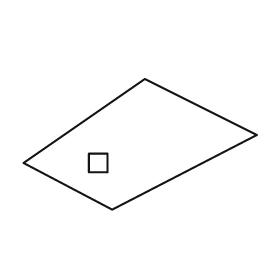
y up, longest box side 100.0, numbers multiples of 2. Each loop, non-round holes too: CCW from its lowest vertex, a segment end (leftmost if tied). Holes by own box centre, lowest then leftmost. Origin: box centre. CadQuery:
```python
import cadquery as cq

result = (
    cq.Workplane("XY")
    .moveTo(-12.0, -28.0)
    .lineTo(50.0, 4.0)
    .lineTo(2.0, 28.0)
    .lineTo(-50.0, -8.0)
    .close()
    .moveTo(-22.0, -12.0)
    .lineTo(-14.0, -12.0)
    .lineTo(-14.0, -4.0)
    .lineTo(-22.0, -4.0)
    .close()
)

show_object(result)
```